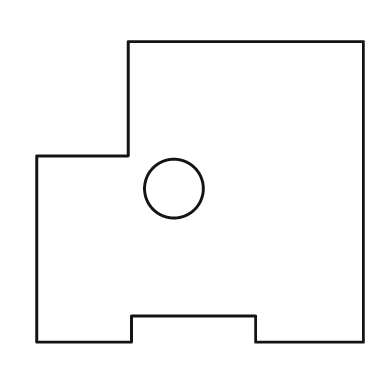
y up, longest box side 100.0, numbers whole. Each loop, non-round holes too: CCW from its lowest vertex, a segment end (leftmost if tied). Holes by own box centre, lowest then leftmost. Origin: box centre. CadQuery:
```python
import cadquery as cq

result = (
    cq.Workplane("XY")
    .moveTo(-50.0, -46.0)
    .lineTo(-21.0, -46.0)
    .lineTo(-21.0, -38.0)
    .lineTo(17.0, -38.0)
    .lineTo(17.0, -46.0)
    .lineTo(50.0, -46.0)
    .lineTo(50.0, 46.0)
    .lineTo(-22.0, 46.0)
    .lineTo(-22.0, 11.0)
    .lineTo(-50.0, 11.0)
    .close()
    .moveTo(-8.0, 1.0)
    .circle(9.0)
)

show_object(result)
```